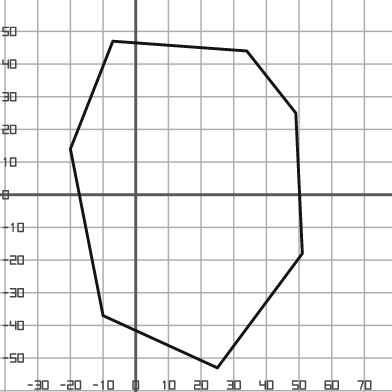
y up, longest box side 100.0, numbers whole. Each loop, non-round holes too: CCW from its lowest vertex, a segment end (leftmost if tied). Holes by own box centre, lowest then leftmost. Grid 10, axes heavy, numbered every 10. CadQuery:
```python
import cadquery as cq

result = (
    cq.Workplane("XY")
    .moveTo(25.0, -53.0)
    .lineTo(51.0, -18.0)
    .lineTo(49.0, 25.0)
    .lineTo(34.0, 44.0)
    .lineTo(-7.0, 47.0)
    .lineTo(-20.0, 14.0)
    .lineTo(-10.0, -37.0)
    .close()
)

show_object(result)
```